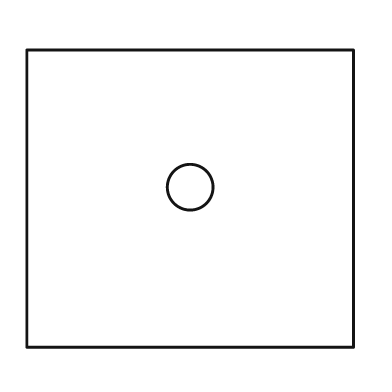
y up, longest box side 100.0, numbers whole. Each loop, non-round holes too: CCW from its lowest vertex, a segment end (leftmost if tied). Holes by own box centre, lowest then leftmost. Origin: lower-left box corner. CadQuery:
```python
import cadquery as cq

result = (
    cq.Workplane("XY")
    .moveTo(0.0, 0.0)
    .lineTo(100.0, 0.0)
    .lineTo(100.0, 91.0)
    .lineTo(0.0, 91.0)
    .close()
    .moveTo(50.0, 49.0)
    .circle(7.0)
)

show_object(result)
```